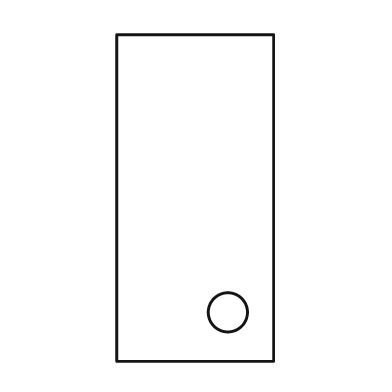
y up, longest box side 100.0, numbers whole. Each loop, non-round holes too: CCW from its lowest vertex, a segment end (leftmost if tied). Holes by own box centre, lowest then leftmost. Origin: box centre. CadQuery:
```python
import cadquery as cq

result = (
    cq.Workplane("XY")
    .moveTo(-24.0, -50.0)
    .lineTo(24.0, -50.0)
    .lineTo(24.0, 50.0)
    .lineTo(-24.0, 50.0)
    .close()
    .moveTo(10.0, -35.0)
    .circle(6.0)
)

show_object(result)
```